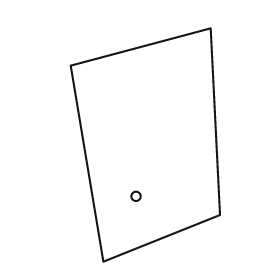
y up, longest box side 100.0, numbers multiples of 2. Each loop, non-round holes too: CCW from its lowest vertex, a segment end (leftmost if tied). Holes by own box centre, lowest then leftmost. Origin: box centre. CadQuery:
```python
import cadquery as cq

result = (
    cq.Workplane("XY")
    .moveTo(-18.0, -50.0)
    .lineTo(32.0, -30.0)
    .lineTo(28.0, 50.0)
    .lineTo(-32.0, 34.0)
    .close()
    .moveTo(-4.0, -22.0)
    .circle(2.0)
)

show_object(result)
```